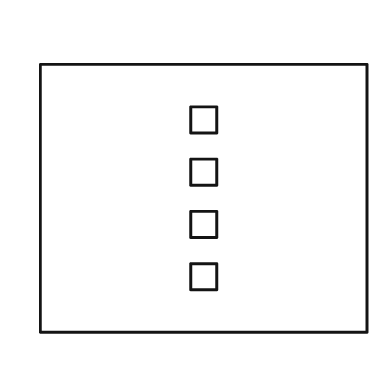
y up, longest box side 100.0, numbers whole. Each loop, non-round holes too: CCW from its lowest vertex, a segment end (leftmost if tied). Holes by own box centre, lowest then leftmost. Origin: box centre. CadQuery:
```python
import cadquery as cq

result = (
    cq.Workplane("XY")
    .moveTo(-50.0, -41.0)
    .lineTo(50.0, -41.0)
    .lineTo(50.0, 41.0)
    .lineTo(-50.0, 41.0)
    .close()
    .moveTo(-4.0, -28.0)
    .lineTo(4.0, -28.0)
    .lineTo(4.0, -20.0)
    .lineTo(-4.0, -20.0)
    .close()
    .moveTo(-4.0, -12.0)
    .lineTo(4.0, -12.0)
    .lineTo(4.0, -4.0)
    .lineTo(-4.0, -4.0)
    .close()
    .moveTo(-4.0, 4.0)
    .lineTo(4.0, 4.0)
    .lineTo(4.0, 12.0)
    .lineTo(-4.0, 12.0)
    .close()
    .moveTo(-4.0, 20.0)
    .lineTo(4.0, 20.0)
    .lineTo(4.0, 28.0)
    .lineTo(-4.0, 28.0)
    .close()
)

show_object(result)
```